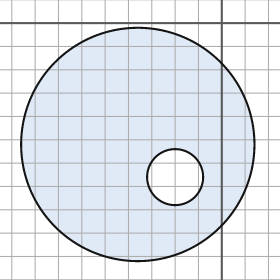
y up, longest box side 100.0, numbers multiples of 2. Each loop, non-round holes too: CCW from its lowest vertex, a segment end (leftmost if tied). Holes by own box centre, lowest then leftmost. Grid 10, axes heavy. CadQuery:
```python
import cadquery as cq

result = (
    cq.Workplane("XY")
    .moveTo(-36.0, -52.0)
    .circle(50.0)
    .moveTo(-20.0, -66.0)
    .circle(12.0)
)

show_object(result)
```